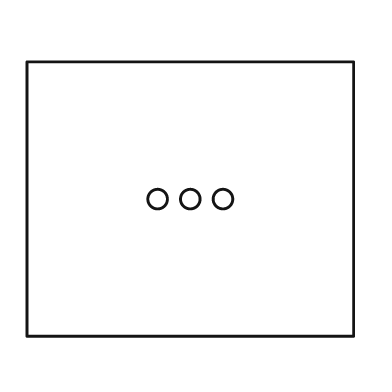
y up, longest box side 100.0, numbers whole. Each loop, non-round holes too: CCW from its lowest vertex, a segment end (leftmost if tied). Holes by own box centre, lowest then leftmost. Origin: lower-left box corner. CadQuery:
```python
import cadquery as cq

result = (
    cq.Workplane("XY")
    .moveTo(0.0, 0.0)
    .lineTo(100.0, 0.0)
    .lineTo(100.0, 84.0)
    .lineTo(0.0, 84.0)
    .close()
    .moveTo(40.0, 42.0)
    .circle(3.0)
    .moveTo(50.0, 42.0)
    .circle(3.0)
    .moveTo(60.0, 42.0)
    .circle(3.0)
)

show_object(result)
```